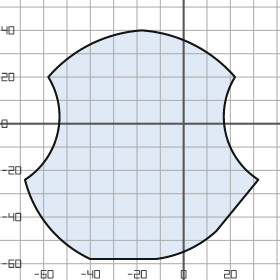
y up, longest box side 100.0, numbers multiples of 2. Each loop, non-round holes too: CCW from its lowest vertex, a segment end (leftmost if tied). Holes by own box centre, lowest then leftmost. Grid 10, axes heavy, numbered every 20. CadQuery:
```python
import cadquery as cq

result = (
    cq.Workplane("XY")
    .moveTo(-40.0, -58.0)
    .lineTo(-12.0, -58.0)
    .threePointArc((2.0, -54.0), (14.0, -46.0))
    .lineTo(32.0, -24.0)
    .threePointArc((18.0, -4.0), (22.0, 20.0))
    .threePointArc((4.0, 34.0), (-18.0, 40.0))
    .threePointArc((-40.0, 34.0), (-58.0, 20.0))
    .threePointArc((-54.0, -4.0), (-68.0, -24.0))
    .threePointArc((-58.0, -44.0), (-40.0, -58.0))
    .close()
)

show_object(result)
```